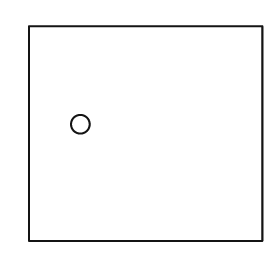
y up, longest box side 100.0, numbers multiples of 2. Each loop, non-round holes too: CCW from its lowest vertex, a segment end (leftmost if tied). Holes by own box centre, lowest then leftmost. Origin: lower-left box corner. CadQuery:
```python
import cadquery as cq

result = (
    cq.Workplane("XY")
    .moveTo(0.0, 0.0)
    .lineTo(100.0, 0.0)
    .lineTo(100.0, 92.0)
    .lineTo(0.0, 92.0)
    .close()
    .moveTo(22.0, 50.0)
    .circle(4.0)
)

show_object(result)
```